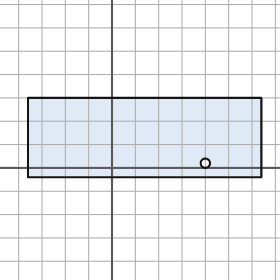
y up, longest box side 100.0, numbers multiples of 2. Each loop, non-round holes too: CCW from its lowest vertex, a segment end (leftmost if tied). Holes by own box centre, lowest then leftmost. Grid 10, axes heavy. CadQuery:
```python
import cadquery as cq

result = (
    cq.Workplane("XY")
    .moveTo(-36.0, -4.0)
    .lineTo(64.0, -4.0)
    .lineTo(64.0, 30.0)
    .lineTo(-36.0, 30.0)
    .close()
    .moveTo(40.0, 2.0)
    .circle(2.0)
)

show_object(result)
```